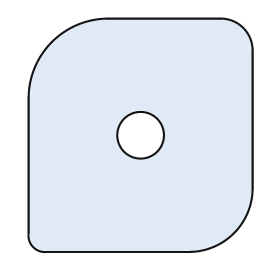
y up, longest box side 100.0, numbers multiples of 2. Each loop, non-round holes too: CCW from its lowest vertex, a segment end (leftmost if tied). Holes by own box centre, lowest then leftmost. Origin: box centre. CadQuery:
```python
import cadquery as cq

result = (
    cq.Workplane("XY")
    .moveTo(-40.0, -50.0)
    .lineTo(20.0, -50.0)
    .threePointArc((40.0, -42.0), (48.0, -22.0))
    .lineTo(48.0, 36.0)
    .threePointArc((44.0, 46.0), (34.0, 50.0))
    .lineTo(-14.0, 50.0)
    .threePointArc((-38.0, 40.0), (-48.0, 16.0))
    .lineTo(-48.0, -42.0)
    .threePointArc((-46.0, -48.0), (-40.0, -50.0))
    .close()
    .moveTo(0.0, 0.0)
    .circle(10.0)
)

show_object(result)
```